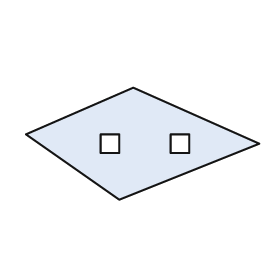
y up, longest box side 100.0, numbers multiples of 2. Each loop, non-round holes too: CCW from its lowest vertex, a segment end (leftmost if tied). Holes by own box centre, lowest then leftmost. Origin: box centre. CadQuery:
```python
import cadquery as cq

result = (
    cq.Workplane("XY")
    .moveTo(-10.0, -24.0)
    .lineTo(50.0, 0.0)
    .lineTo(-4.0, 24.0)
    .lineTo(-50.0, 4.0)
    .close()
    .moveTo(-18.0, -4.0)
    .lineTo(-10.0, -4.0)
    .lineTo(-10.0, 4.0)
    .lineTo(-18.0, 4.0)
    .close()
    .moveTo(12.0, -4.0)
    .lineTo(20.0, -4.0)
    .lineTo(20.0, 4.0)
    .lineTo(12.0, 4.0)
    .close()
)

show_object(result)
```